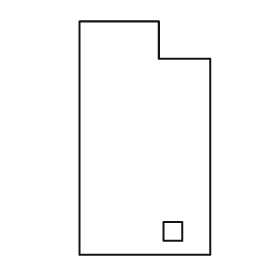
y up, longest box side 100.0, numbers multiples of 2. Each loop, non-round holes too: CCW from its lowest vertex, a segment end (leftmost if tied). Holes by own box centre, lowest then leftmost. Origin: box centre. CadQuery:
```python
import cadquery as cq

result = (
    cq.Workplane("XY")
    .moveTo(-28.0, -50.0)
    .lineTo(28.0, -50.0)
    .lineTo(28.0, 34.0)
    .lineTo(6.0, 34.0)
    .lineTo(6.0, 50.0)
    .lineTo(-28.0, 50.0)
    .close()
    .moveTo(8.0, -44.0)
    .lineTo(16.0, -44.0)
    .lineTo(16.0, -36.0)
    .lineTo(8.0, -36.0)
    .close()
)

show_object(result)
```